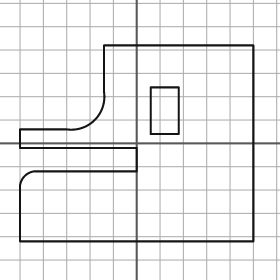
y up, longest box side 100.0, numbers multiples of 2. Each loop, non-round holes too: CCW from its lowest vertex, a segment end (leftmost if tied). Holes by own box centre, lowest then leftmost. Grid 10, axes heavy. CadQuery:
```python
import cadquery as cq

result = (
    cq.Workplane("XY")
    .moveTo(-50.0, -42.0)
    .lineTo(50.0, -42.0)
    .lineTo(50.0, 42.0)
    .lineTo(-14.0, 42.0)
    .lineTo(-14.0, 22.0)
    .threePointArc((-18.0, 10.0), (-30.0, 6.0))
    .lineTo(-50.0, 6.0)
    .lineTo(-50.0, -2.0)
    .lineTo(0.0, -2.0)
    .lineTo(0.0, -12.0)
    .lineTo(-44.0, -12.0)
    .threePointArc((-48.0, -14.0), (-50.0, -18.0))
    .close()
    .moveTo(6.0, 4.0)
    .lineTo(18.0, 4.0)
    .lineTo(18.0, 24.0)
    .lineTo(6.0, 24.0)
    .close()
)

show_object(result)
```